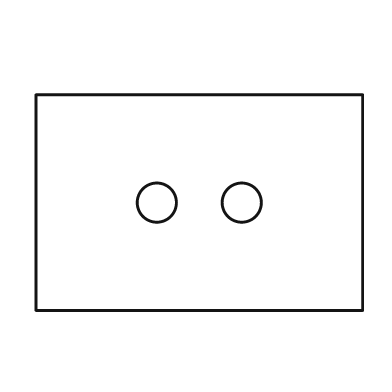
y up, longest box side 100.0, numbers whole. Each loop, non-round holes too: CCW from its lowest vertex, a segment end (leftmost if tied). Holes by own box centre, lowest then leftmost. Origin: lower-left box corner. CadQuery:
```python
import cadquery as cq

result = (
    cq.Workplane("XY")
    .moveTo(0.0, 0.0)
    .lineTo(100.0, 0.0)
    .lineTo(100.0, 66.0)
    .lineTo(0.0, 66.0)
    .close()
    .moveTo(37.0, 33.0)
    .circle(6.0)
    .moveTo(63.0, 33.0)
    .circle(6.0)
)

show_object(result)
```